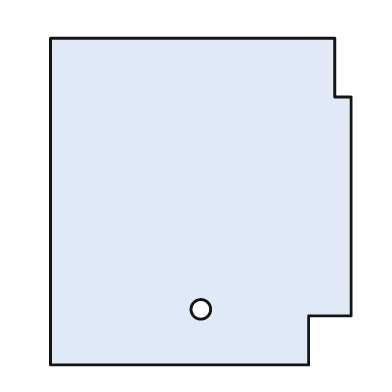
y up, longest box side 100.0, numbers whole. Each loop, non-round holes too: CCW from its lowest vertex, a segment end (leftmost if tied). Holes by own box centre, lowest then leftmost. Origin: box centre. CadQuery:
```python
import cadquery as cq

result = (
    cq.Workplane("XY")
    .moveTo(-46.0, -50.0)
    .lineTo(33.0, -50.0)
    .lineTo(33.0, -35.0)
    .lineTo(46.0, -35.0)
    .lineTo(46.0, 32.0)
    .lineTo(41.0, 32.0)
    .lineTo(41.0, 50.0)
    .lineTo(-46.0, 50.0)
    .close()
    .moveTo(0.0, -33.0)
    .circle(3.0)
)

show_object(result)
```